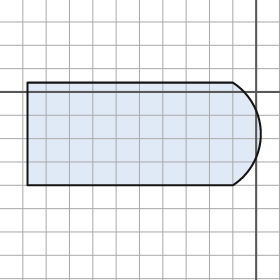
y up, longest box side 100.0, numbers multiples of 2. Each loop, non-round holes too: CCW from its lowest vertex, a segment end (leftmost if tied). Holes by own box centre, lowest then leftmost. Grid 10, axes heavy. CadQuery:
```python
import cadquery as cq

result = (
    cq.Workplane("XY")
    .moveTo(-98.0, -40.0)
    .lineTo(-10.0, -40.0)
    .threePointArc((2.0, -18.0), (-10.0, 4.0))
    .lineTo(-98.0, 4.0)
    .close()
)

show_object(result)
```